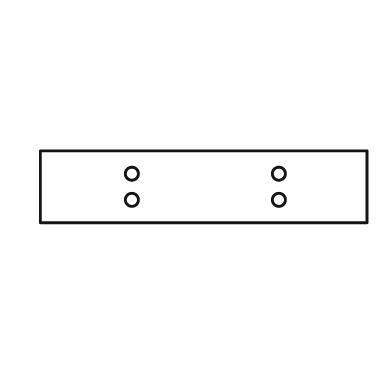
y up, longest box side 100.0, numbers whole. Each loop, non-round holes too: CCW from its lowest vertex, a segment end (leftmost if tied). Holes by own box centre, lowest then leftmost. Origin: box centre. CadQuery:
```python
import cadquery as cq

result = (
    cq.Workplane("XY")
    .moveTo(-50.0, -11.0)
    .lineTo(50.0, -11.0)
    .lineTo(50.0, 11.0)
    .lineTo(-50.0, 11.0)
    .close()
    .moveTo(-22.0, -4.0)
    .circle(2.0)
    .moveTo(23.0, -4.0)
    .circle(2.0)
    .moveTo(-22.0, 4.0)
    .circle(2.0)
    .moveTo(23.0, 4.0)
    .circle(2.0)
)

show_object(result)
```